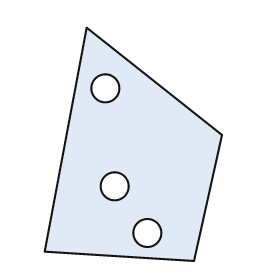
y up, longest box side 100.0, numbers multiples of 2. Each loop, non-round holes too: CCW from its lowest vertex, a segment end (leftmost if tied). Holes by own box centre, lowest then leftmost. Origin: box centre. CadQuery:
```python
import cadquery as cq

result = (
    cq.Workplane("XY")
    .moveTo(26.0, -50.0)
    .lineTo(38.0, 4.0)
    .lineTo(-20.0, 50.0)
    .lineTo(-38.0, -46.0)
    .close()
    .moveTo(6.0, -38.0)
    .circle(6.0)
    .moveTo(-8.0, -18.0)
    .circle(6.0)
    .moveTo(-12.0, 24.0)
    .circle(6.0)
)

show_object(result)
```